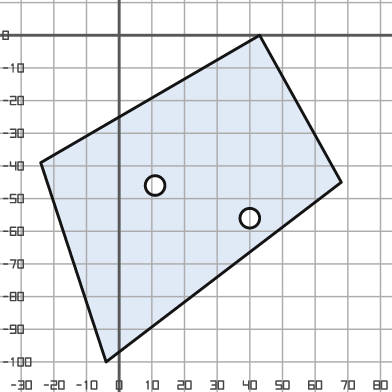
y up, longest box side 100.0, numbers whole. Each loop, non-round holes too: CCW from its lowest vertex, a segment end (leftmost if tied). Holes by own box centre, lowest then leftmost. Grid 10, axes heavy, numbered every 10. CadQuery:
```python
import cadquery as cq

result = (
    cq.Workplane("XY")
    .moveTo(-4.0, -100.0)
    .lineTo(68.0, -45.0)
    .lineTo(43.0, 0.0)
    .lineTo(-24.0, -39.0)
    .close()
    .moveTo(40.0, -56.0)
    .circle(3.0)
    .moveTo(11.0, -46.0)
    .circle(3.0)
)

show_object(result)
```